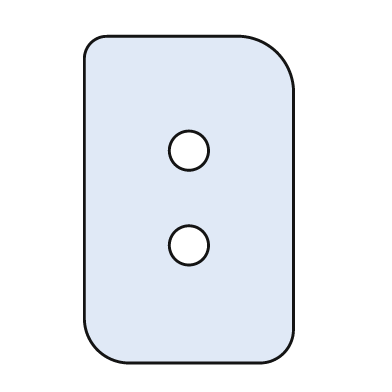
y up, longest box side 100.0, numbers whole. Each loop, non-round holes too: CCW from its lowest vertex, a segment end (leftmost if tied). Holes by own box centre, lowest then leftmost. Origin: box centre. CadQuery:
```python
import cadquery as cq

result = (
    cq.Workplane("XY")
    .moveTo(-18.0, -50.0)
    .lineTo(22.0, -50.0)
    .threePointArc((29.0, -47.0), (32.0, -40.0))
    .lineTo(32.0, 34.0)
    .threePointArc((27.0, 45.0), (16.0, 50.0))
    .lineTo(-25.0, 50.0)
    .threePointArc((-30.0, 48.0), (-32.0, 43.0))
    .lineTo(-32.0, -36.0)
    .threePointArc((-28.0, -46.0), (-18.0, -50.0))
    .close()
    .moveTo(0.0, -14.0)
    .circle(6.0)
    .moveTo(0.0, 15.0)
    .circle(6.0)
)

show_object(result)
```